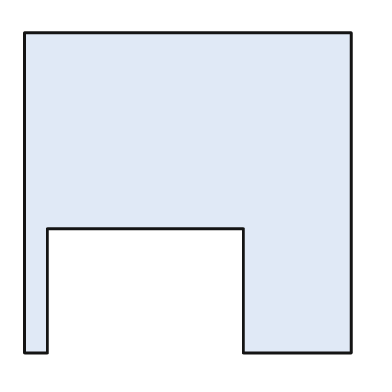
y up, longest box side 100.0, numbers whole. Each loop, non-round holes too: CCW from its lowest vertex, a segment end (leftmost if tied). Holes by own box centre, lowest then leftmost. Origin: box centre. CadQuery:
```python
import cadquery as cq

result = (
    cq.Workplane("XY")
    .moveTo(-50.0, -49.0)
    .lineTo(-43.0, -49.0)
    .lineTo(-43.0, -11.0)
    .lineTo(17.0, -11.0)
    .lineTo(17.0, -49.0)
    .lineTo(50.0, -49.0)
    .lineTo(50.0, 49.0)
    .lineTo(-50.0, 49.0)
    .close()
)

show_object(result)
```